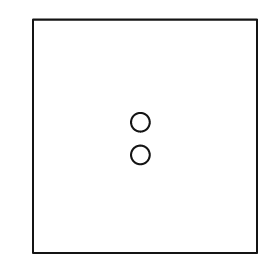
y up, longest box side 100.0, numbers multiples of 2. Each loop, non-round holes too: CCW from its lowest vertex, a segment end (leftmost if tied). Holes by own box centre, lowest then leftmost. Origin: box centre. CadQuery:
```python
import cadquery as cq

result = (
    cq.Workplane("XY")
    .moveTo(-48.0, -50.0)
    .lineTo(48.0, -50.0)
    .lineTo(48.0, 50.0)
    .lineTo(-48.0, 50.0)
    .close()
    .moveTo(-2.0, -8.0)
    .circle(4.0)
    .moveTo(-2.0, 6.0)
    .circle(4.0)
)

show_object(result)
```